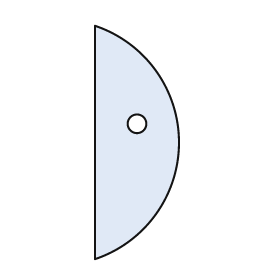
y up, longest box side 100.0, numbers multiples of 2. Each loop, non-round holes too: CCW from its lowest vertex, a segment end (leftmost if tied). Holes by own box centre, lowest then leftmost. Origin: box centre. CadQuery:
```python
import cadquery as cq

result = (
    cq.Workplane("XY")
    .moveTo(-18.0, -50.0)
    .threePointArc((18.0, 0.0), (-18.0, 50.0))
    .close()
    .moveTo(0.0, 8.0)
    .circle(4.0)
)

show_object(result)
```